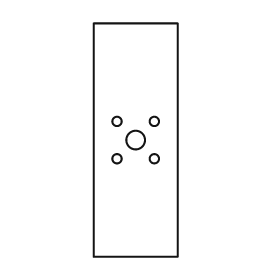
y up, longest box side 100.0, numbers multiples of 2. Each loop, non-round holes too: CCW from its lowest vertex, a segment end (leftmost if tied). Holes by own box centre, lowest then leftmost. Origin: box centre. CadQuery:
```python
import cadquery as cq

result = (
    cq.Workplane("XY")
    .moveTo(-18.0, -50.0)
    .lineTo(18.0, -50.0)
    .lineTo(18.0, 50.0)
    .lineTo(-18.0, 50.0)
    .close()
    .moveTo(-8.0, -8.0)
    .circle(2.0)
    .moveTo(8.0, -8.0)
    .circle(2.0)
    .moveTo(0.0, 0.0)
    .circle(4.0)
    .moveTo(-8.0, 8.0)
    .circle(2.0)
    .moveTo(8.0, 8.0)
    .circle(2.0)
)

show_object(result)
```